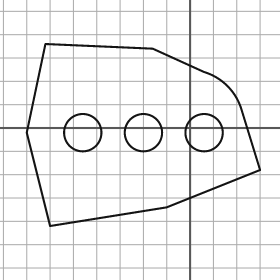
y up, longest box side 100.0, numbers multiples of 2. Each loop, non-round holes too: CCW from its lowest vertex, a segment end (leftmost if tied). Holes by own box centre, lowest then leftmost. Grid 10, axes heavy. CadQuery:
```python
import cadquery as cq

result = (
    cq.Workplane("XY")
    .moveTo(-60.0, -42.0)
    .lineTo(-10.0, -34.0)
    .lineTo(30.0, -18.0)
    .lineTo(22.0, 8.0)
    .threePointArc((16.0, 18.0), (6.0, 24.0))
    .lineTo(-16.0, 34.0)
    .lineTo(-62.0, 36.0)
    .lineTo(-70.0, -2.0)
    .close()
    .moveTo(-46.0, -2.0)
    .circle(8.0)
    .moveTo(-20.0, -2.0)
    .circle(8.0)
    .moveTo(6.0, -2.0)
    .circle(8.0)
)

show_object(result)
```